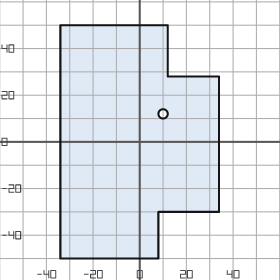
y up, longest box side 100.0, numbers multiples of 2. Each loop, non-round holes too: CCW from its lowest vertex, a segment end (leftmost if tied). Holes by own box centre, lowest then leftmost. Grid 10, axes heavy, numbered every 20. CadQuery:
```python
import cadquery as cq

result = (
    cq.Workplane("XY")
    .moveTo(-34.0, -50.0)
    .lineTo(8.0, -50.0)
    .lineTo(8.0, -30.0)
    .lineTo(34.0, -30.0)
    .lineTo(34.0, 28.0)
    .lineTo(12.0, 28.0)
    .lineTo(12.0, 50.0)
    .lineTo(-34.0, 50.0)
    .close()
    .moveTo(10.0, 12.0)
    .circle(2.0)
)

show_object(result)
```